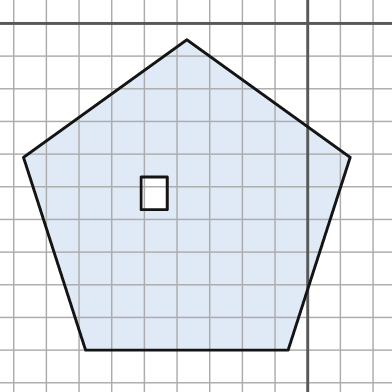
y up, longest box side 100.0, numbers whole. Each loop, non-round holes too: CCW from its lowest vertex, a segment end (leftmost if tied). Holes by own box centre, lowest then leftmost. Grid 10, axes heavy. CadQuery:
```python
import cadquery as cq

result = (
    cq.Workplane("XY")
    .moveTo(-68.0, -100.0)
    .lineTo(-6.0, -100.0)
    .lineTo(13.0, -41.0)
    .lineTo(-37.0, -5.0)
    .lineTo(-87.0, -41.0)
    .close()
    .moveTo(-51.0, -57.0)
    .lineTo(-43.0, -57.0)
    .lineTo(-43.0, -47.0)
    .lineTo(-51.0, -47.0)
    .close()
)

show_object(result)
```